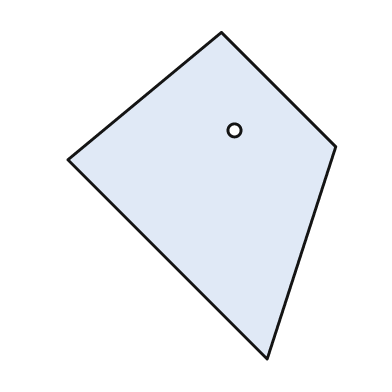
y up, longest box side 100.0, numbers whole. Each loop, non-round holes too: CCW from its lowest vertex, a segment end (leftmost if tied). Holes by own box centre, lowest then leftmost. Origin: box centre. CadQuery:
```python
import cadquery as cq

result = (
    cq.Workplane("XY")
    .moveTo(20.0, -50.0)
    .lineTo(41.0, 15.0)
    .lineTo(6.0, 50.0)
    .lineTo(-41.0, 11.0)
    .close()
    .moveTo(10.0, 20.0)
    .circle(2.0)
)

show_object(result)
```